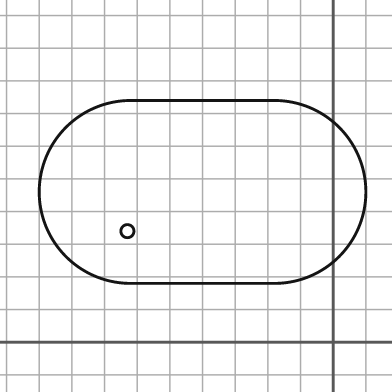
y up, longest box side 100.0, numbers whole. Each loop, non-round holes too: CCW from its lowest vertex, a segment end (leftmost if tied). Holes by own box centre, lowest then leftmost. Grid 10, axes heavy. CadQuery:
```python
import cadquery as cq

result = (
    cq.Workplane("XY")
    .moveTo(-62.0, 18.0)
    .lineTo(-18.0, 18.0)
    .threePointArc((10.0, 46.0), (-18.0, 74.0))
    .lineTo(-62.0, 74.0)
    .threePointArc((-90.0, 46.0), (-62.0, 18.0))
    .close()
    .moveTo(-63.0, 34.0)
    .circle(2.0)
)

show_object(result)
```